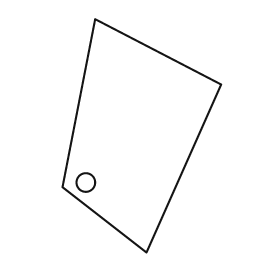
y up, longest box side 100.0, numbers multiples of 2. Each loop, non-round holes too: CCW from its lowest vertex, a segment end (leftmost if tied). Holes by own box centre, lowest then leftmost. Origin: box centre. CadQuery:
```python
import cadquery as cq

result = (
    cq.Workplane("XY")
    .moveTo(2.0, -50.0)
    .lineTo(34.0, 22.0)
    .lineTo(-20.0, 50.0)
    .lineTo(-34.0, -22.0)
    .close()
    .moveTo(-24.0, -20.0)
    .circle(4.0)
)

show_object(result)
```